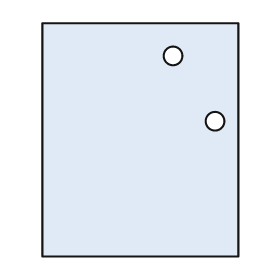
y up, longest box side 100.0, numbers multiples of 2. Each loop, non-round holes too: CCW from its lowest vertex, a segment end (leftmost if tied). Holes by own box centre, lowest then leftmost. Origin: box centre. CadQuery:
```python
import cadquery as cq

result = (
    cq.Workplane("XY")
    .moveTo(-42.0, -50.0)
    .lineTo(42.0, -50.0)
    .lineTo(42.0, 50.0)
    .lineTo(-42.0, 50.0)
    .close()
    .moveTo(32.0, 8.0)
    .circle(4.0)
    .moveTo(14.0, 36.0)
    .circle(4.0)
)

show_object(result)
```